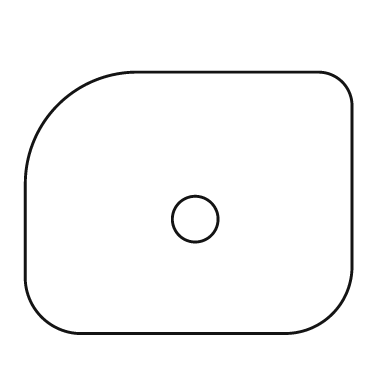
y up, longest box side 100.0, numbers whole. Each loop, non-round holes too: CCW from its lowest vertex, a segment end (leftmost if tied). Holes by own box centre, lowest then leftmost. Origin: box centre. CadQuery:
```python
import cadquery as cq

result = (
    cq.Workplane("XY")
    .moveTo(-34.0, -40.0)
    .lineTo(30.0, -40.0)
    .threePointArc((44.0, -34.0), (50.0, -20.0))
    .lineTo(50.0, 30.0)
    .threePointArc((47.0, 37.0), (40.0, 40.0))
    .lineTo(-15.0, 40.0)
    .threePointArc((-40.0, 30.0), (-50.0, 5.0))
    .lineTo(-50.0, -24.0)
    .threePointArc((-45.0, -35.0), (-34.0, -40.0))
    .close()
    .moveTo(2.0, -5.0)
    .circle(7.0)
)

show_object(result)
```